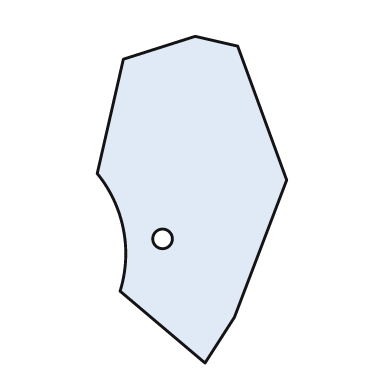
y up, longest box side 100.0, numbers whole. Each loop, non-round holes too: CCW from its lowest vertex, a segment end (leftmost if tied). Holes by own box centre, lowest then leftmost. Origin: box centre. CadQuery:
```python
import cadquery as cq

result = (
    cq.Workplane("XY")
    .moveTo(4.0, -50.0)
    .lineTo(13.0, -36.0)
    .lineTo(29.0, 6.0)
    .lineTo(14.0, 47.0)
    .lineTo(1.0, 50.0)
    .lineTo(-21.0, 43.0)
    .lineTo(-29.0, 8.0)
    .threePointArc((-21.0, -9.0), (-22.0, -28.0))
    .close()
    .moveTo(-9.0, -12.0)
    .circle(3.0)
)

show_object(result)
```